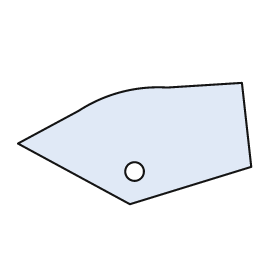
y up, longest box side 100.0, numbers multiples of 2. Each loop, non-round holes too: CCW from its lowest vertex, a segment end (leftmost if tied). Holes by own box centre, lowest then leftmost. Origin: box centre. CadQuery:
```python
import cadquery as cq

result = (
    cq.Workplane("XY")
    .moveTo(-2.0, -26.0)
    .lineTo(50.0, -10.0)
    .lineTo(46.0, 26.0)
    .lineTo(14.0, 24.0)
    .threePointArc((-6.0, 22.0), (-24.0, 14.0))
    .lineTo(-50.0, 0.0)
    .close()
    .moveTo(0.0, -12.0)
    .circle(4.0)
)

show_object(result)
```